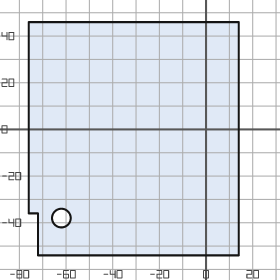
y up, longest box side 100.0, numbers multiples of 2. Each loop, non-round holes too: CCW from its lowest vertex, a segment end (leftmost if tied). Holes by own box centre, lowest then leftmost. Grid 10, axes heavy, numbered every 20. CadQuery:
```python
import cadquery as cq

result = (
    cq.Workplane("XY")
    .moveTo(-72.0, -54.0)
    .lineTo(14.0, -54.0)
    .lineTo(14.0, 46.0)
    .lineTo(-76.0, 46.0)
    .lineTo(-76.0, -36.0)
    .lineTo(-72.0, -36.0)
    .close()
    .moveTo(-62.0, -38.0)
    .circle(4.0)
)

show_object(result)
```